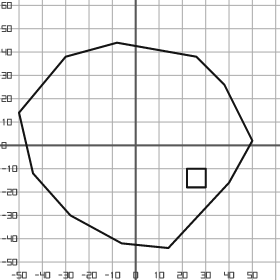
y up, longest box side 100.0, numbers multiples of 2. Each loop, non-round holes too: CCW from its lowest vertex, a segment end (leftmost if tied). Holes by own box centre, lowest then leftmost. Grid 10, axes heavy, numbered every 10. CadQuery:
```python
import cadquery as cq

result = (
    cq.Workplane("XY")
    .moveTo(14.0, -44.0)
    .lineTo(40.0, -16.0)
    .lineTo(50.0, 2.0)
    .lineTo(38.0, 26.0)
    .lineTo(26.0, 38.0)
    .lineTo(-8.0, 44.0)
    .lineTo(-30.0, 38.0)
    .lineTo(-50.0, 14.0)
    .lineTo(-44.0, -12.0)
    .lineTo(-28.0, -30.0)
    .lineTo(-6.0, -42.0)
    .close()
    .moveTo(22.0, -18.0)
    .lineTo(30.0, -18.0)
    .lineTo(30.0, -10.0)
    .lineTo(22.0, -10.0)
    .close()
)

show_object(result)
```